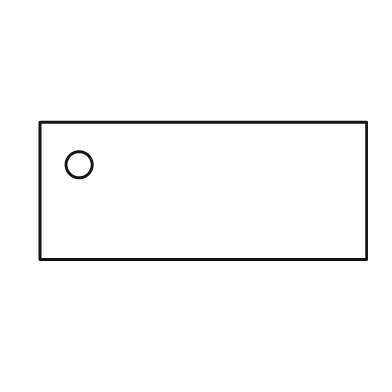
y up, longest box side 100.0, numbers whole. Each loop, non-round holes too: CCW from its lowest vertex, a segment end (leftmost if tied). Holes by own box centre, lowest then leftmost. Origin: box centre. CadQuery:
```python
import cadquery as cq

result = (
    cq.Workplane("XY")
    .moveTo(-50.0, -21.0)
    .lineTo(50.0, -21.0)
    .lineTo(50.0, 21.0)
    .lineTo(-50.0, 21.0)
    .close()
    .moveTo(-38.0, 8.0)
    .circle(4.0)
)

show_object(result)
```